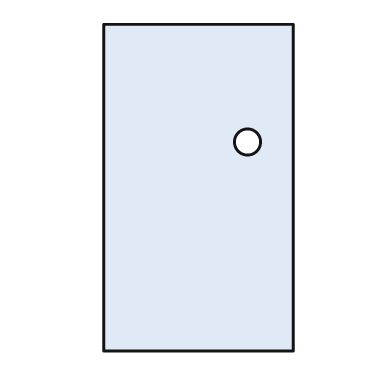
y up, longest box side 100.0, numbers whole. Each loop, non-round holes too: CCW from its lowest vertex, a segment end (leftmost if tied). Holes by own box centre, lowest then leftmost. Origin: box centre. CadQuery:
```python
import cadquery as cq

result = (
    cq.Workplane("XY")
    .moveTo(-29.0, -50.0)
    .lineTo(29.0, -50.0)
    .lineTo(29.0, 50.0)
    .lineTo(-29.0, 50.0)
    .close()
    .moveTo(15.0, 14.0)
    .circle(4.0)
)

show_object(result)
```